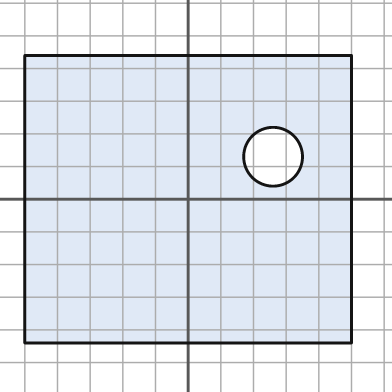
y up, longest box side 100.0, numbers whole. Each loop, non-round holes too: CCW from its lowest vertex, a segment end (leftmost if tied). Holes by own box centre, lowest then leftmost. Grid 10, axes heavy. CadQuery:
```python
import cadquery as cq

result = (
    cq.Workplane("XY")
    .moveTo(-50.0, -44.0)
    .lineTo(50.0, -44.0)
    .lineTo(50.0, 44.0)
    .lineTo(-50.0, 44.0)
    .close()
    .moveTo(26.0, 13.0)
    .circle(9.0)
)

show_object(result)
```